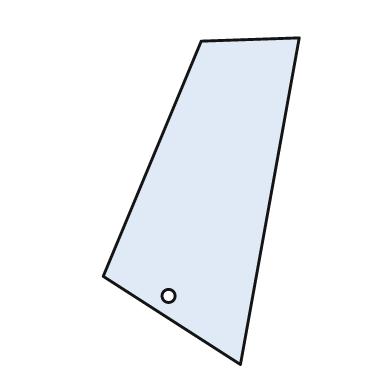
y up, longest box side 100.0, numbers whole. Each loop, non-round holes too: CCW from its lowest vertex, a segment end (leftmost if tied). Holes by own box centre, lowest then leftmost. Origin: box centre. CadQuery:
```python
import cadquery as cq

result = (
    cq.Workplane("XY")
    .moveTo(12.0, -50.0)
    .lineTo(30.0, 50.0)
    .lineTo(0.0, 49.0)
    .lineTo(-30.0, -23.0)
    .close()
    .moveTo(-10.0, -29.0)
    .circle(2.0)
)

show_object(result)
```